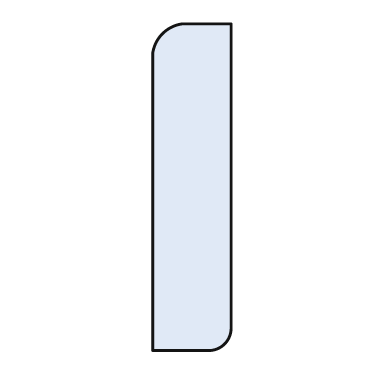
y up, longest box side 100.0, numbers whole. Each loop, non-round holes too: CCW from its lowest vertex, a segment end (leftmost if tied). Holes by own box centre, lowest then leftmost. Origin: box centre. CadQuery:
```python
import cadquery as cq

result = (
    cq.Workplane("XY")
    .moveTo(-12.0, -50.0)
    .lineTo(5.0, -50.0)
    .threePointArc((10.0, -48.0), (12.0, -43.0))
    .lineTo(12.0, 50.0)
    .lineTo(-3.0, 50.0)
    .threePointArc((-9.0, 47.0), (-12.0, 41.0))
    .close()
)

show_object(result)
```